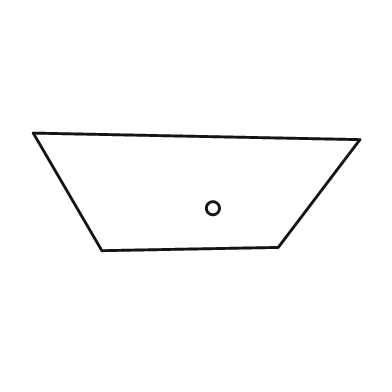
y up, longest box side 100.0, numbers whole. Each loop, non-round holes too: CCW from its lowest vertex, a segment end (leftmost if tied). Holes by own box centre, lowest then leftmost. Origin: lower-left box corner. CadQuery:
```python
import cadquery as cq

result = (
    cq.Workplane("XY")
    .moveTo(21.0, 0.0)
    .lineTo(75.0, 1.0)
    .lineTo(100.0, 34.0)
    .lineTo(0.0, 36.0)
    .close()
    .moveTo(55.0, 13.0)
    .circle(2.0)
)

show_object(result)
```